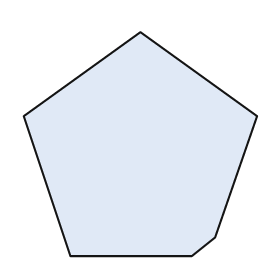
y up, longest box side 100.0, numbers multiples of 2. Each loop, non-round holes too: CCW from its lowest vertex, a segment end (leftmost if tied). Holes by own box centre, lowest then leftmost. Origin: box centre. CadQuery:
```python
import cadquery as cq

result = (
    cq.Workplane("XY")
    .moveTo(-30.0, -48.0)
    .lineTo(22.0, -48.0)
    .lineTo(32.0, -40.0)
    .lineTo(50.0, 12.0)
    .lineTo(0.0, 48.0)
    .lineTo(-50.0, 12.0)
    .close()
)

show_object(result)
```